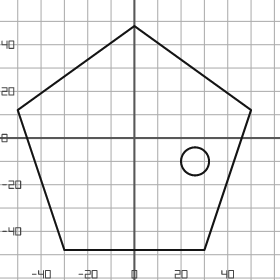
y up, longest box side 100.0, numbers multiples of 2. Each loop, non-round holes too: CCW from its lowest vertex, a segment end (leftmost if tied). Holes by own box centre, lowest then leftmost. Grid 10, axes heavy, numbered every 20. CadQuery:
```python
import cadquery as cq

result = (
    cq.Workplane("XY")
    .moveTo(-30.0, -48.0)
    .lineTo(30.0, -48.0)
    .lineTo(50.0, 12.0)
    .lineTo(0.0, 48.0)
    .lineTo(-50.0, 12.0)
    .close()
    .moveTo(26.0, -10.0)
    .circle(6.0)
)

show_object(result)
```